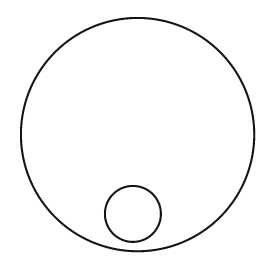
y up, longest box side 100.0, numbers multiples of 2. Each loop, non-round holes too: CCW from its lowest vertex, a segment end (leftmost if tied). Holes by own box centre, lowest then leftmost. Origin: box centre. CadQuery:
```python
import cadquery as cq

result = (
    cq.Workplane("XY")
    .moveTo(0.0, 0.0)
    .circle(50.0)
    .moveTo(-2.0, -34.0)
    .circle(12.0)
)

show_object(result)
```